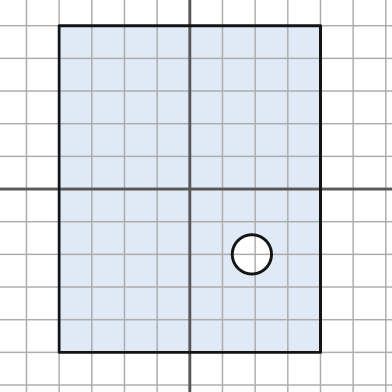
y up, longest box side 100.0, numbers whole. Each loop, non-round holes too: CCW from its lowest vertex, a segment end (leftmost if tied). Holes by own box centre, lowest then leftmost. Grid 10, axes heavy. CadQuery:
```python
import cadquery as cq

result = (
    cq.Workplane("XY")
    .moveTo(-40.0, -50.0)
    .lineTo(40.0, -50.0)
    .lineTo(40.0, 50.0)
    .lineTo(-40.0, 50.0)
    .close()
    .moveTo(19.0, -20.0)
    .circle(6.0)
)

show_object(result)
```